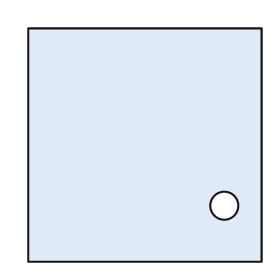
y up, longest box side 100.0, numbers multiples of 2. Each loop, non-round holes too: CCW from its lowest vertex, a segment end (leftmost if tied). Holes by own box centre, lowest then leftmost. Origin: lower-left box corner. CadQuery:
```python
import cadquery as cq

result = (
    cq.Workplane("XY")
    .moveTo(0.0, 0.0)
    .lineTo(100.0, 0.0)
    .lineTo(100.0, 100.0)
    .lineTo(0.0, 100.0)
    .close()
    .moveTo(84.0, 24.0)
    .circle(6.0)
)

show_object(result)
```